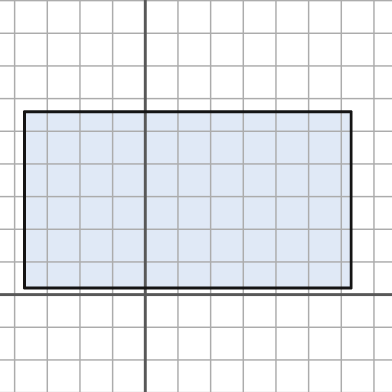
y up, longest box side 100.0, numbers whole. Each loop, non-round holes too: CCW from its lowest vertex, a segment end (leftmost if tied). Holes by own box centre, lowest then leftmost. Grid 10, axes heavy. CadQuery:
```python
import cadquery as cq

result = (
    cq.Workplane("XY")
    .moveTo(-37.0, 2.0)
    .lineTo(63.0, 2.0)
    .lineTo(63.0, 56.0)
    .lineTo(-37.0, 56.0)
    .close()
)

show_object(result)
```